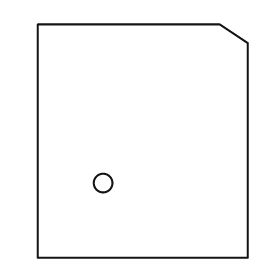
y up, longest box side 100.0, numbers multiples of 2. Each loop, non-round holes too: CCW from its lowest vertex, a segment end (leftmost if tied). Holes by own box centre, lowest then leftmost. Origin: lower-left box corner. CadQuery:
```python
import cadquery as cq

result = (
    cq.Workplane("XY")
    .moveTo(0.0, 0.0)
    .lineTo(90.0, 0.0)
    .lineTo(90.0, 92.0)
    .lineTo(78.0, 100.0)
    .lineTo(0.0, 100.0)
    .close()
    .moveTo(28.0, 32.0)
    .circle(4.0)
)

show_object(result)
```